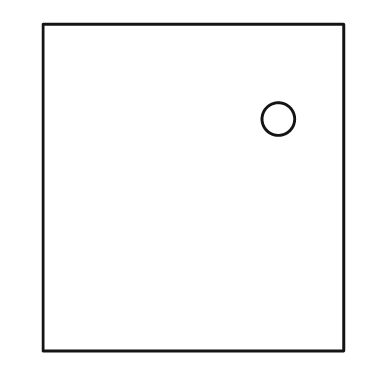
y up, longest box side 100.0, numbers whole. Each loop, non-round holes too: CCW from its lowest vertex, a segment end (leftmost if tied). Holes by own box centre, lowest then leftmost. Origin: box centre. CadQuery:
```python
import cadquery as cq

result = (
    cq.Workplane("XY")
    .moveTo(-46.0, -50.0)
    .lineTo(46.0, -50.0)
    .lineTo(46.0, 50.0)
    .lineTo(-46.0, 50.0)
    .close()
    .moveTo(26.0, 21.0)
    .circle(5.0)
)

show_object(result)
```